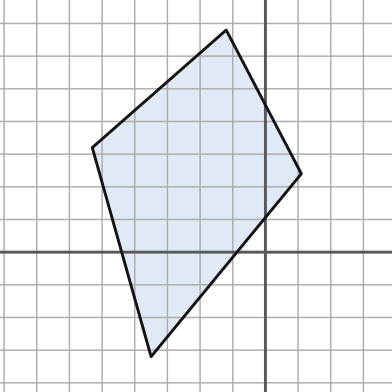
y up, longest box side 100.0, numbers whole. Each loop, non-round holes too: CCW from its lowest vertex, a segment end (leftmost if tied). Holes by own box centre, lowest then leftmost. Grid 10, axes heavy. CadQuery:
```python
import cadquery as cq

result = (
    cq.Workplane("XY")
    .moveTo(-35.0, -32.0)
    .lineTo(11.0, 24.0)
    .lineTo(-12.0, 68.0)
    .lineTo(-53.0, 32.0)
    .close()
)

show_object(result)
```